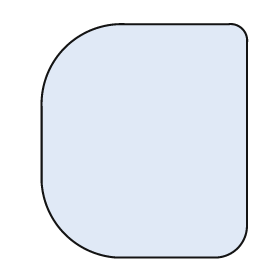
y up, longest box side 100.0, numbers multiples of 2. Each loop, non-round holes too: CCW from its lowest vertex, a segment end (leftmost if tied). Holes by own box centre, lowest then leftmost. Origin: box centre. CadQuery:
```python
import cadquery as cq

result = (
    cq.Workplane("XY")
    .moveTo(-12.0, -50.0)
    .lineTo(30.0, -50.0)
    .threePointArc((40.0, -46.0), (44.0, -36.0))
    .lineTo(44.0, 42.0)
    .threePointArc((42.0, 48.0), (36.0, 50.0))
    .lineTo(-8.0, 50.0)
    .threePointArc((-34.0, 40.0), (-44.0, 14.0))
    .lineTo(-44.0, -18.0)
    .threePointArc((-34.0, -40.0), (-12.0, -50.0))
    .close()
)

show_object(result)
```